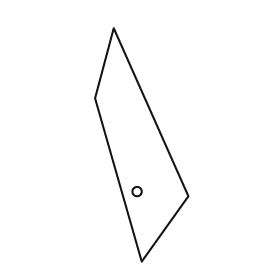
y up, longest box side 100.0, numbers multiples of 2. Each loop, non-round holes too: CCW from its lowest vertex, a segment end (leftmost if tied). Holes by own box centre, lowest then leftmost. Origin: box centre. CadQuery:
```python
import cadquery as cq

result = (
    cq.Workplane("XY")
    .moveTo(0.0, -50.0)
    .lineTo(20.0, -22.0)
    .lineTo(-12.0, 50.0)
    .lineTo(-20.0, 20.0)
    .close()
    .moveTo(-2.0, -20.0)
    .circle(2.0)
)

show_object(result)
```